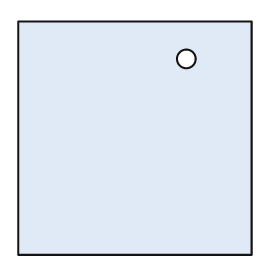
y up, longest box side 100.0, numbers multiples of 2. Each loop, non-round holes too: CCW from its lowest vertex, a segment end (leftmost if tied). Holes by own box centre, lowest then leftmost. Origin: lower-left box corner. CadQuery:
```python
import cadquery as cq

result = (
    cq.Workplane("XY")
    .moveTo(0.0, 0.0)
    .lineTo(100.0, 0.0)
    .lineTo(100.0, 100.0)
    .lineTo(0.0, 100.0)
    .close()
    .moveTo(72.0, 84.0)
    .circle(4.0)
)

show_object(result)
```